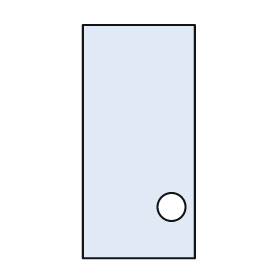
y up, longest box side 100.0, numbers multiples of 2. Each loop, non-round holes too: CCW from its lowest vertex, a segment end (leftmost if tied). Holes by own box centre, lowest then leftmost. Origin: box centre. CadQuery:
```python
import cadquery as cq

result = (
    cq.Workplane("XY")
    .moveTo(-24.0, -50.0)
    .lineTo(24.0, -50.0)
    .lineTo(24.0, 50.0)
    .lineTo(-24.0, 50.0)
    .close()
    .moveTo(14.0, -28.0)
    .circle(6.0)
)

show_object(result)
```